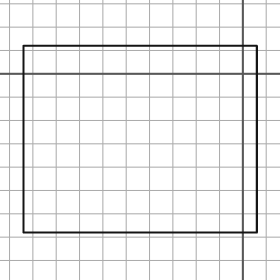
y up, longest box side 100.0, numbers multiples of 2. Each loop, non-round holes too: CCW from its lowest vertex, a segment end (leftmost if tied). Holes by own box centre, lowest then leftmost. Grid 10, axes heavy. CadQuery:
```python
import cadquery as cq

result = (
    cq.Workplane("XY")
    .moveTo(-94.0, -68.0)
    .lineTo(6.0, -68.0)
    .lineTo(6.0, 12.0)
    .lineTo(-94.0, 12.0)
    .close()
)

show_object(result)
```